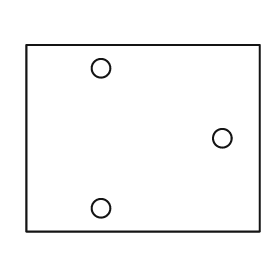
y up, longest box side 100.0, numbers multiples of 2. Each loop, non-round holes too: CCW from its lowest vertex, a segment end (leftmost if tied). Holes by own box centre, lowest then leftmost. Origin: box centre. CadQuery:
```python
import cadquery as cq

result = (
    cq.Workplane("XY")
    .moveTo(-50.0, -40.0)
    .lineTo(50.0, -40.0)
    .lineTo(50.0, 40.0)
    .lineTo(-50.0, 40.0)
    .close()
    .moveTo(-18.0, -30.0)
    .circle(4.0)
    .moveTo(34.0, 0.0)
    .circle(4.0)
    .moveTo(-18.0, 30.0)
    .circle(4.0)
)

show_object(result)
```